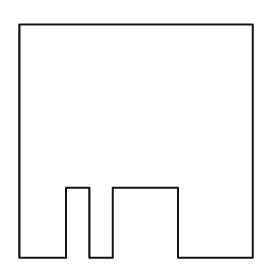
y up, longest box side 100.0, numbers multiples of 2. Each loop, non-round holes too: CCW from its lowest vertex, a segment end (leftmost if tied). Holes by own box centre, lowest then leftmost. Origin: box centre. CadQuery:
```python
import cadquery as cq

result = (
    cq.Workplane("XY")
    .moveTo(-50.0, -50.0)
    .lineTo(-30.0, -50.0)
    .lineTo(-30.0, -20.0)
    .lineTo(-20.0, -20.0)
    .lineTo(-20.0, -50.0)
    .lineTo(-10.0, -50.0)
    .lineTo(-10.0, -20.0)
    .lineTo(18.0, -20.0)
    .lineTo(18.0, -50.0)
    .lineTo(50.0, -50.0)
    .lineTo(50.0, 50.0)
    .lineTo(-50.0, 50.0)
    .close()
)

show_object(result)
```